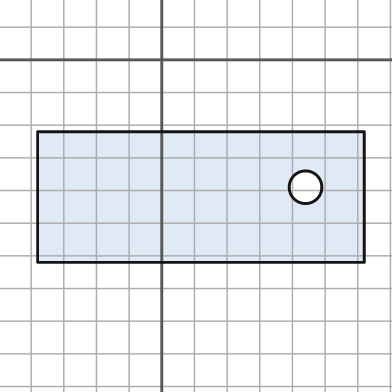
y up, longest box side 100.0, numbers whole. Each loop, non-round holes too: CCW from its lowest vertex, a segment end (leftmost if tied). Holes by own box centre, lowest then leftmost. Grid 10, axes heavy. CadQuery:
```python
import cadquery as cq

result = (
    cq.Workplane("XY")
    .moveTo(-38.0, -62.0)
    .lineTo(62.0, -62.0)
    .lineTo(62.0, -22.0)
    .lineTo(-38.0, -22.0)
    .close()
    .moveTo(44.0, -39.0)
    .circle(5.0)
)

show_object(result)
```